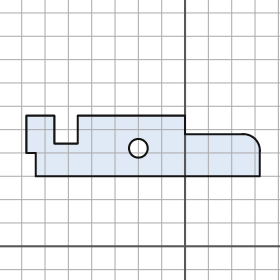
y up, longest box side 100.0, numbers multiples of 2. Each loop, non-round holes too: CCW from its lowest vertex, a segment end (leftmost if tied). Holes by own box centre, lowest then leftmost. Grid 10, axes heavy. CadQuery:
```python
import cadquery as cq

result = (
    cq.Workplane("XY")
    .moveTo(-64.0, 30.0)
    .lineTo(32.0, 30.0)
    .lineTo(32.0, 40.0)
    .threePointArc((30.0, 46.0), (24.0, 48.0))
    .lineTo(0.0, 48.0)
    .lineTo(0.0, 56.0)
    .lineTo(-46.0, 56.0)
    .lineTo(-46.0, 44.0)
    .lineTo(-56.0, 44.0)
    .lineTo(-56.0, 56.0)
    .lineTo(-68.0, 56.0)
    .lineTo(-68.0, 40.0)
    .lineTo(-64.0, 40.0)
    .close()
    .moveTo(-20.0, 42.0)
    .circle(4.0)
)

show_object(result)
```